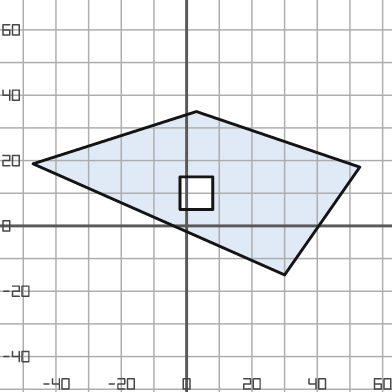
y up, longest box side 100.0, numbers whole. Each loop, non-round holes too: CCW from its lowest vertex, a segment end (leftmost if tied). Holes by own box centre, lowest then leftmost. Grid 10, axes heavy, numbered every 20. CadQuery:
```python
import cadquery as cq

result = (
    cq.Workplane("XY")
    .moveTo(30.0, -15.0)
    .lineTo(53.0, 18.0)
    .lineTo(3.0, 35.0)
    .lineTo(-47.0, 19.0)
    .close()
    .moveTo(-2.0, 5.0)
    .lineTo(8.0, 5.0)
    .lineTo(8.0, 15.0)
    .lineTo(-2.0, 15.0)
    .close()
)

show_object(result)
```